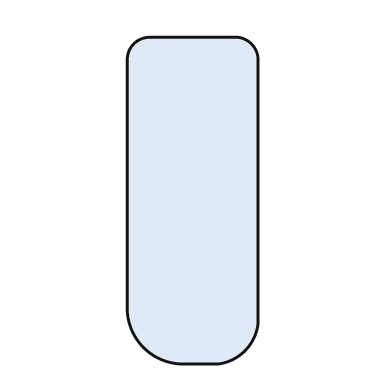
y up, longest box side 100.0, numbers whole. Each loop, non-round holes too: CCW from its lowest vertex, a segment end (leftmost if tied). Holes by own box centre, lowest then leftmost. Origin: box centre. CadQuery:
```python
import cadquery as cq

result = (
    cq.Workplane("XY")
    .moveTo(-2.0, -50.0)
    .lineTo(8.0, -50.0)
    .threePointArc((16.0, -46.0), (20.0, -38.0))
    .lineTo(20.0, 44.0)
    .threePointArc((18.0, 48.0), (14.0, 50.0))
    .lineTo(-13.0, 50.0)
    .threePointArc((-18.0, 48.0), (-20.0, 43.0))
    .lineTo(-20.0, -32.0)
    .threePointArc((-15.0, -45.0), (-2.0, -50.0))
    .close()
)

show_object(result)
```